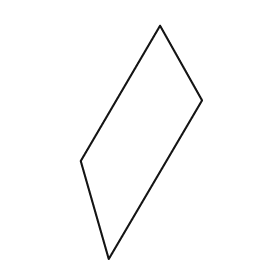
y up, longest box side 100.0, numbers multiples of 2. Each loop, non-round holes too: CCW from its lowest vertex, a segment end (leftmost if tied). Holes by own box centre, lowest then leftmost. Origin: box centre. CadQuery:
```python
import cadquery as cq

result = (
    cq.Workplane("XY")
    .moveTo(-14.0, -50.0)
    .lineTo(26.0, 18.0)
    .lineTo(8.0, 50.0)
    .lineTo(-26.0, -8.0)
    .close()
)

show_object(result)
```